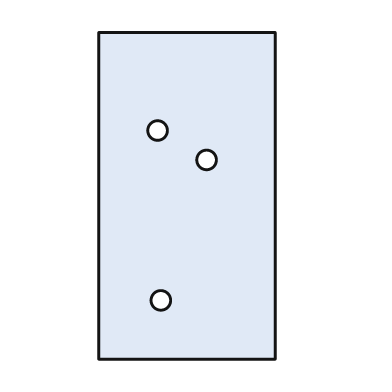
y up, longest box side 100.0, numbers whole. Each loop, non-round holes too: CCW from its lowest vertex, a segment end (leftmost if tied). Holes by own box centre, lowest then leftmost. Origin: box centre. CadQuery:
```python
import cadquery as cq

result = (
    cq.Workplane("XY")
    .moveTo(-27.0, -50.0)
    .lineTo(27.0, -50.0)
    .lineTo(27.0, 50.0)
    .lineTo(-27.0, 50.0)
    .close()
    .moveTo(-8.0, -32.0)
    .circle(3.0)
    .moveTo(6.0, 11.0)
    .circle(3.0)
    .moveTo(-9.0, 20.0)
    .circle(3.0)
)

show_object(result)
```